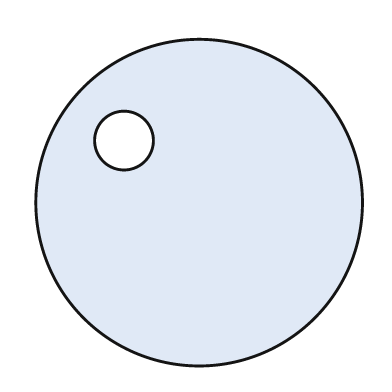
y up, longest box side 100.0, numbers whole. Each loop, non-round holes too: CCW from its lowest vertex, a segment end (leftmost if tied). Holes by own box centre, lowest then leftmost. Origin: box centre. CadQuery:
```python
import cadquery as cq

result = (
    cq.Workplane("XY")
    .moveTo(0.0, 0.0)
    .circle(50.0)
    .moveTo(-23.0, 19.0)
    .circle(9.0)
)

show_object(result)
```